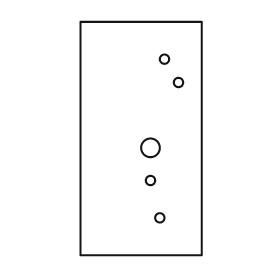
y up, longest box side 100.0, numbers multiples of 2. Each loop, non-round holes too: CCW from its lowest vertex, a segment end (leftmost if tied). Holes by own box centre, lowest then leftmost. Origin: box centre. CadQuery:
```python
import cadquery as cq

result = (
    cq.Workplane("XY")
    .moveTo(-26.0, -50.0)
    .lineTo(26.0, -50.0)
    .lineTo(26.0, 50.0)
    .lineTo(-26.0, 50.0)
    .close()
    .moveTo(8.0, -34.0)
    .circle(2.0)
    .moveTo(4.0, -18.0)
    .circle(2.0)
    .moveTo(4.0, -4.0)
    .circle(4.0)
    .moveTo(16.0, 24.0)
    .circle(2.0)
    .moveTo(10.0, 34.0)
    .circle(2.0)
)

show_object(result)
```